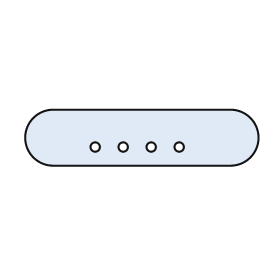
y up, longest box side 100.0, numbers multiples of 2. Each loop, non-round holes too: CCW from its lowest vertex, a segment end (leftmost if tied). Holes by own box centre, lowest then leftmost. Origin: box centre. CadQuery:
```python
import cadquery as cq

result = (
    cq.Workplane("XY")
    .moveTo(-38.0, -12.0)
    .lineTo(38.0, -12.0)
    .threePointArc((50.0, 0.0), (38.0, 12.0))
    .lineTo(-38.0, 12.0)
    .threePointArc((-50.0, 0.0), (-38.0, -12.0))
    .close()
    .moveTo(-20.0, -4.0)
    .circle(2.0)
    .moveTo(-8.0, -4.0)
    .circle(2.0)
    .moveTo(4.0, -4.0)
    .circle(2.0)
    .moveTo(16.0, -4.0)
    .circle(2.0)
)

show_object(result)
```